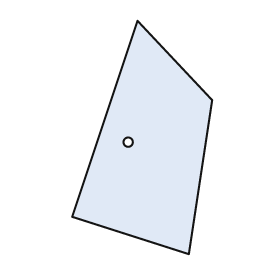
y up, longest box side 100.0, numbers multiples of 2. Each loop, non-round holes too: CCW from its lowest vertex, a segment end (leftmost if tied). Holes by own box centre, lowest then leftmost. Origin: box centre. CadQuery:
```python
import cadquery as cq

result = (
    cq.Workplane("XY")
    .moveTo(20.0, -50.0)
    .lineTo(30.0, 16.0)
    .lineTo(-2.0, 50.0)
    .lineTo(-30.0, -34.0)
    .close()
    .moveTo(-6.0, -2.0)
    .circle(2.0)
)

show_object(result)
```